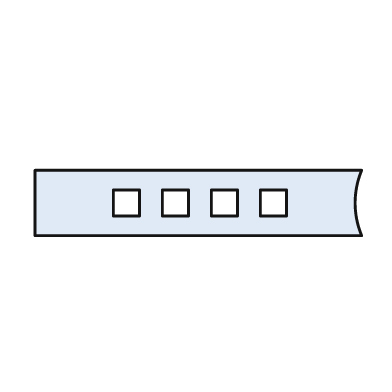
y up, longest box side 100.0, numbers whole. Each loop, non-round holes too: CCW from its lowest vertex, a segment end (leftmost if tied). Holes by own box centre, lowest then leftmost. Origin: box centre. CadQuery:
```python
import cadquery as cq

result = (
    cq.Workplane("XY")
    .moveTo(-50.0, -10.0)
    .lineTo(50.0, -10.0)
    .threePointArc((48.0, 0.0), (50.0, 10.0))
    .lineTo(-50.0, 10.0)
    .close()
    .moveTo(-26.0, -4.0)
    .lineTo(-18.0, -4.0)
    .lineTo(-18.0, 4.0)
    .lineTo(-26.0, 4.0)
    .close()
    .moveTo(-11.0, -4.0)
    .lineTo(-3.0, -4.0)
    .lineTo(-3.0, 4.0)
    .lineTo(-11.0, 4.0)
    .close()
    .moveTo(4.0, -4.0)
    .lineTo(12.0, -4.0)
    .lineTo(12.0, 4.0)
    .lineTo(4.0, 4.0)
    .close()
    .moveTo(19.0, -4.0)
    .lineTo(27.0, -4.0)
    .lineTo(27.0, 4.0)
    .lineTo(19.0, 4.0)
    .close()
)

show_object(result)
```